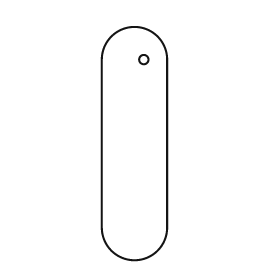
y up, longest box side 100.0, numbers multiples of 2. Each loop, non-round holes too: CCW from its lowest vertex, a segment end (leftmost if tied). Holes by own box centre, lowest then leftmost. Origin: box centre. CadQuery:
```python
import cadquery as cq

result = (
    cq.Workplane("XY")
    .moveTo(-14.0, -36.0)
    .threePointArc((0.0, -50.0), (14.0, -36.0))
    .lineTo(14.0, 36.0)
    .threePointArc((0.0, 50.0), (-14.0, 36.0))
    .close()
    .moveTo(4.0, 36.0)
    .circle(2.0)
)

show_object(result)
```